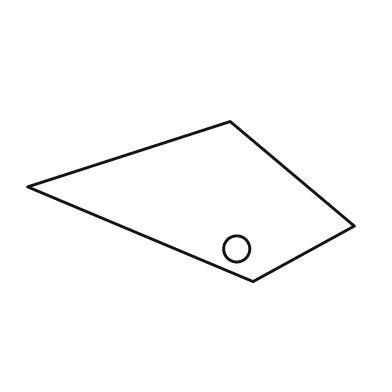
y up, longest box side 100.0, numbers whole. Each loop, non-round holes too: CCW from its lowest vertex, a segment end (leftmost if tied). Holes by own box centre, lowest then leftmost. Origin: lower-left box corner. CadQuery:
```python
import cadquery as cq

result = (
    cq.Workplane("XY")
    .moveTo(69.0, 0.0)
    .lineTo(100.0, 17.0)
    .lineTo(62.0, 49.0)
    .lineTo(0.0, 29.0)
    .close()
    .moveTo(64.0, 10.0)
    .circle(4.0)
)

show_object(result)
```